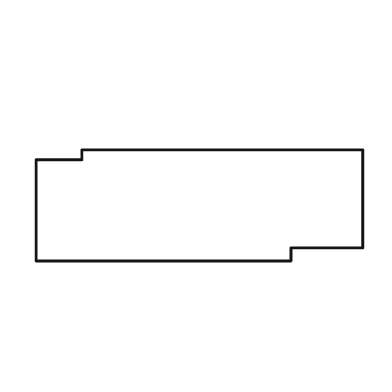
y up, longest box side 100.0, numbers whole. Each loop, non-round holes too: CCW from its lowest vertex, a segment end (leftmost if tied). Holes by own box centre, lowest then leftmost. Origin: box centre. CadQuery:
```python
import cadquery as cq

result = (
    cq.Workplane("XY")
    .moveTo(-50.0, -17.0)
    .lineTo(28.0, -17.0)
    .lineTo(28.0, -13.0)
    .lineTo(50.0, -13.0)
    .lineTo(50.0, 17.0)
    .lineTo(-36.0, 17.0)
    .lineTo(-36.0, 14.0)
    .lineTo(-50.0, 14.0)
    .close()
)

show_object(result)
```